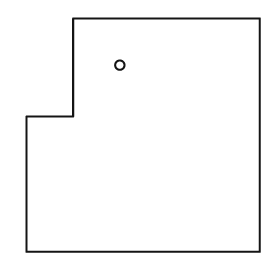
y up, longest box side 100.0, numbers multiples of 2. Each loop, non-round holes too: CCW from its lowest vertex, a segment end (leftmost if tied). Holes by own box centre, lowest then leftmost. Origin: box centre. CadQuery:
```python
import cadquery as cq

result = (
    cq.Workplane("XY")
    .moveTo(-50.0, -50.0)
    .lineTo(50.0, -50.0)
    .lineTo(50.0, 50.0)
    .lineTo(-30.0, 50.0)
    .lineTo(-30.0, 8.0)
    .lineTo(-50.0, 8.0)
    .close()
    .moveTo(-10.0, 30.0)
    .circle(2.0)
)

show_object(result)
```